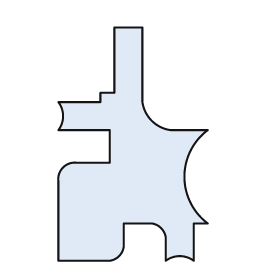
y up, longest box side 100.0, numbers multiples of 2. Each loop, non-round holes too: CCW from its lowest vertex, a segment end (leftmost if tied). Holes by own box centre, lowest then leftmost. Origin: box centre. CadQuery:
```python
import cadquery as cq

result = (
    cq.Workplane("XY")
    .moveTo(-32.0, -50.0)
    .lineTo(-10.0, -50.0)
    .threePointArc((-6.0, -48.0), (-4.0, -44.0))
    .lineTo(-4.0, -34.0)
    .lineTo(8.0, -34.0)
    .threePointArc((12.0, -36.0), (14.0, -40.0))
    .lineTo(14.0, -50.0)
    .threePointArc((20.0, -48.0), (26.0, -50.0))
    .lineTo(26.0, -34.0)
    .lineTo(32.0, -34.0)
    .threePointArc((22.0, -14.0), (32.0, 6.0))
    .lineTo(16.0, 6.0)
    .threePointArc((8.0, 10.0), (4.0, 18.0))
    .lineTo(4.0, 50.0)
    .lineTo(-8.0, 50.0)
    .lineTo(-8.0, 22.0)
    .lineTo(-14.0, 22.0)
    .lineTo(-14.0, 18.0)
    .lineTo(-32.0, 18.0)
    .threePointArc((-30.0, 12.0), (-32.0, 6.0))
    .lineTo(-10.0, 6.0)
    .lineTo(-10.0, -8.0)
    .lineTo(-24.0, -8.0)
    .threePointArc((-30.0, -10.0), (-32.0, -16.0))
    .close()
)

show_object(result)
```